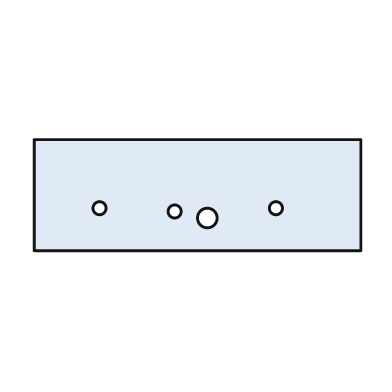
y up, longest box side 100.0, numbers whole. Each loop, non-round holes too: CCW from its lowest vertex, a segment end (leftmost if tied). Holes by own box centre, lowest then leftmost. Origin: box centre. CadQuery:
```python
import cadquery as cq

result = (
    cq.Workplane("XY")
    .moveTo(-50.0, -17.0)
    .lineTo(50.0, -17.0)
    .lineTo(50.0, 17.0)
    .lineTo(-50.0, 17.0)
    .close()
    .moveTo(3.0, -7.0)
    .circle(3.0)
    .moveTo(-7.0, -5.0)
    .circle(2.0)
    .moveTo(-30.0, -4.0)
    .circle(2.0)
    .moveTo(24.0, -4.0)
    .circle(2.0)
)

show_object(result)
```